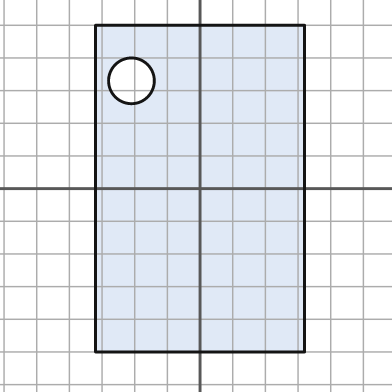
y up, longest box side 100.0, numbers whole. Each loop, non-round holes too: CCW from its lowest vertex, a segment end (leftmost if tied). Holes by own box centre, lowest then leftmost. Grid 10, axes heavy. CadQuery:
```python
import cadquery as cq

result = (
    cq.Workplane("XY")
    .moveTo(-32.0, -50.0)
    .lineTo(32.0, -50.0)
    .lineTo(32.0, 50.0)
    .lineTo(-32.0, 50.0)
    .close()
    .moveTo(-21.0, 33.0)
    .circle(7.0)
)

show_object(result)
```